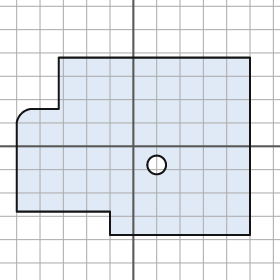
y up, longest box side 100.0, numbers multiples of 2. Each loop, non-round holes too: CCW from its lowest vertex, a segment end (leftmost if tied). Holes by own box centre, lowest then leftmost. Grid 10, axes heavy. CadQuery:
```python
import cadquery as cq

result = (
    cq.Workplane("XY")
    .moveTo(-10.0, -38.0)
    .lineTo(50.0, -38.0)
    .lineTo(50.0, 38.0)
    .lineTo(-32.0, 38.0)
    .lineTo(-32.0, 16.0)
    .lineTo(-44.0, 16.0)
    .threePointArc((-48.0, 14.0), (-50.0, 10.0))
    .lineTo(-50.0, -28.0)
    .lineTo(-10.0, -28.0)
    .close()
    .moveTo(10.0, -8.0)
    .circle(4.0)
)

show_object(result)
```